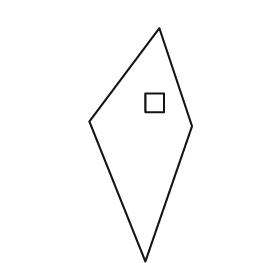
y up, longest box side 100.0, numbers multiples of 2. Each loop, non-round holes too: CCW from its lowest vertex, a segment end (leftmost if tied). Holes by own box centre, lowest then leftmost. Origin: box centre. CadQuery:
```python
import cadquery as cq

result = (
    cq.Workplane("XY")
    .moveTo(2.0, -50.0)
    .lineTo(22.0, 8.0)
    .lineTo(8.0, 50.0)
    .lineTo(-22.0, 10.0)
    .close()
    .moveTo(2.0, 14.0)
    .lineTo(10.0, 14.0)
    .lineTo(10.0, 22.0)
    .lineTo(2.0, 22.0)
    .close()
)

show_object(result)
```